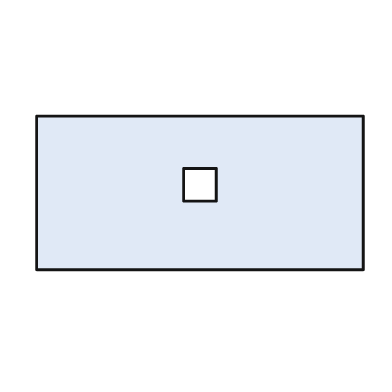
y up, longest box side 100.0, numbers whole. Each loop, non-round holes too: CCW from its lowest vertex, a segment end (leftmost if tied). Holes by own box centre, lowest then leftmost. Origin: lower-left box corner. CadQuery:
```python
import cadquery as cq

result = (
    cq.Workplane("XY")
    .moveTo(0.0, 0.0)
    .lineTo(100.0, 0.0)
    .lineTo(100.0, 47.0)
    .lineTo(0.0, 47.0)
    .close()
    .moveTo(45.0, 21.0)
    .lineTo(55.0, 21.0)
    .lineTo(55.0, 31.0)
    .lineTo(45.0, 31.0)
    .close()
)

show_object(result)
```